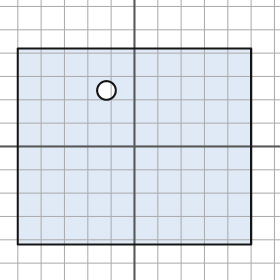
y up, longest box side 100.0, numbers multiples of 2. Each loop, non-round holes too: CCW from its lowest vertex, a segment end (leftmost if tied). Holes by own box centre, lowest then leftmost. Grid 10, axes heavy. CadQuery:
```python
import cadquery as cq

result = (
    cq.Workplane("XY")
    .moveTo(-50.0, -42.0)
    .lineTo(50.0, -42.0)
    .lineTo(50.0, 42.0)
    .lineTo(-50.0, 42.0)
    .close()
    .moveTo(-12.0, 24.0)
    .circle(4.0)
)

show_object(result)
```